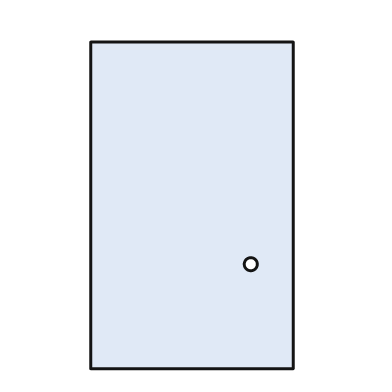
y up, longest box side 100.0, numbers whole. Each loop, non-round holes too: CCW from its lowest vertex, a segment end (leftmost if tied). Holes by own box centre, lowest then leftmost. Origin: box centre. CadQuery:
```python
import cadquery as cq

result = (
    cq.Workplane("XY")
    .moveTo(-31.0, -50.0)
    .lineTo(31.0, -50.0)
    .lineTo(31.0, 50.0)
    .lineTo(-31.0, 50.0)
    .close()
    .moveTo(18.0, -18.0)
    .circle(2.0)
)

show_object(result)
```